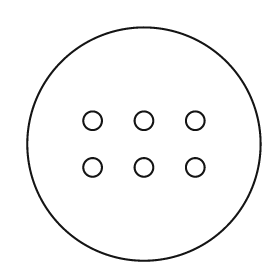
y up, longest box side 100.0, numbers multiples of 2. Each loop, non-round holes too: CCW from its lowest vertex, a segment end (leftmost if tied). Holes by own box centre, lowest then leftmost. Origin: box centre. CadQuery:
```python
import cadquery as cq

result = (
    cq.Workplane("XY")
    .moveTo(0.0, 0.0)
    .circle(50.0)
    .moveTo(-22.0, -10.0)
    .circle(4.0)
    .moveTo(0.0, -10.0)
    .circle(4.0)
    .moveTo(22.0, -10.0)
    .circle(4.0)
    .moveTo(-22.0, 10.0)
    .circle(4.0)
    .moveTo(0.0, 10.0)
    .circle(4.0)
    .moveTo(22.0, 10.0)
    .circle(4.0)
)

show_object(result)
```